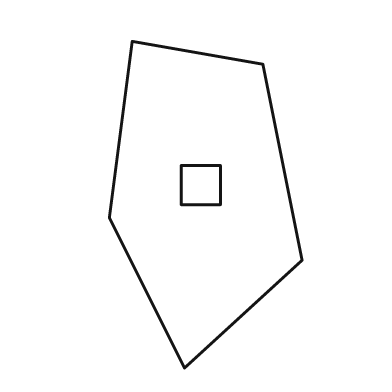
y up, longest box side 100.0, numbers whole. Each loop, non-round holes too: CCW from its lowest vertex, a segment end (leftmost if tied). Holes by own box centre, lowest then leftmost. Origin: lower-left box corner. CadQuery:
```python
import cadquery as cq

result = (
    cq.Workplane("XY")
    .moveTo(23.0, 0.0)
    .lineTo(59.0, 33.0)
    .lineTo(47.0, 93.0)
    .lineTo(7.0, 100.0)
    .lineTo(0.0, 46.0)
    .close()
    .moveTo(22.0, 50.0)
    .lineTo(34.0, 50.0)
    .lineTo(34.0, 62.0)
    .lineTo(22.0, 62.0)
    .close()
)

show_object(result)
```